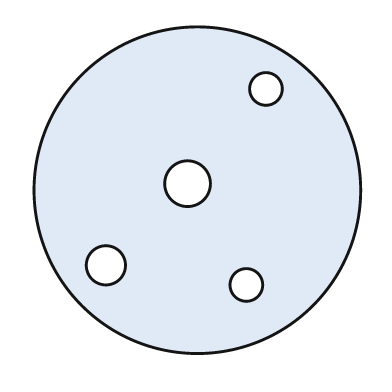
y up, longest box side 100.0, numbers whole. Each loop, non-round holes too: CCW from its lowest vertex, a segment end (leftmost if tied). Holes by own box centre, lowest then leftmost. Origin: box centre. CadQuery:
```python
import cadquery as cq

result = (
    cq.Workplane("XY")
    .moveTo(0.0, 0.0)
    .circle(50.0)
    .moveTo(15.0, -29.0)
    .circle(5.0)
    .moveTo(-28.0, -23.0)
    .circle(6.0)
    .moveTo(-3.0, 2.0)
    .circle(7.0)
    .moveTo(21.0, 31.0)
    .circle(5.0)
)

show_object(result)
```